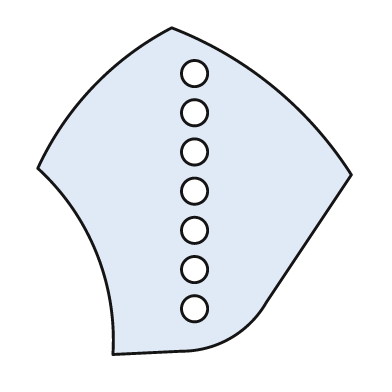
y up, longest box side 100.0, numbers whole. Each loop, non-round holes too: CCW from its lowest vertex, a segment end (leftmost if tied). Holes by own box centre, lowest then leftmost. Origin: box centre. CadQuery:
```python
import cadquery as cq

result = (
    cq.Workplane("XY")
    .moveTo(-25.0, -50.0)
    .lineTo(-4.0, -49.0)
    .threePointArc((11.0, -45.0), (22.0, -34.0))
    .lineTo(48.0, 5.0)
    .threePointArc((24.0, 32.0), (-7.0, 50.0))
    .threePointArc((-31.0, 32.0), (-48.0, 7.0))
    .threePointArc((-30.0, -19.0), (-25.0, -50.0))
    .close()
    .moveTo(0.0, -36.0)
    .circle(4.0)
    .moveTo(0.0, -24.0)
    .circle(4.0)
    .moveTo(0.0, -12.0)
    .circle(4.0)
    .moveTo(0.0, 0.0)
    .circle(4.0)
    .moveTo(0.0, 12.0)
    .circle(4.0)
    .moveTo(0.0, 24.0)
    .circle(4.0)
    .moveTo(0.0, 36.0)
    .circle(4.0)
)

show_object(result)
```